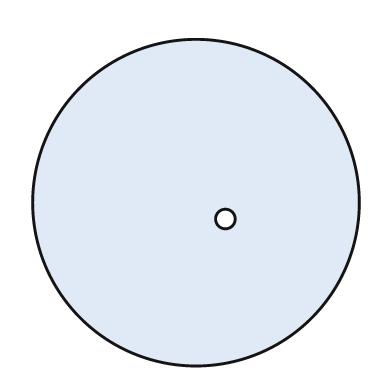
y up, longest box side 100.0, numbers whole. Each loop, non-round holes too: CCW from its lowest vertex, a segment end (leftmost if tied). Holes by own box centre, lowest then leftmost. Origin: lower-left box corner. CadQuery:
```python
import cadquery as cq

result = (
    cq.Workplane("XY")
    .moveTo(50.0, 50.0)
    .circle(50.0)
    .moveTo(59.0, 45.0)
    .circle(3.0)
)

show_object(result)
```